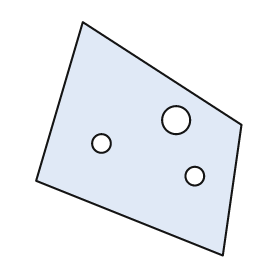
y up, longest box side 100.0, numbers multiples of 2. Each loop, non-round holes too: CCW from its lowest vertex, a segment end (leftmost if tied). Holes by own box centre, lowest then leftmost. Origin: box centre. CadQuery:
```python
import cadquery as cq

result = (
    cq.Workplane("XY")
    .moveTo(36.0, -50.0)
    .lineTo(44.0, 6.0)
    .lineTo(-24.0, 50.0)
    .lineTo(-44.0, -18.0)
    .close()
    .moveTo(24.0, -16.0)
    .circle(4.0)
    .moveTo(-16.0, -2.0)
    .circle(4.0)
    .moveTo(16.0, 8.0)
    .circle(6.0)
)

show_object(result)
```